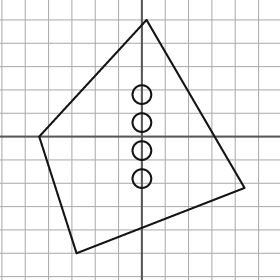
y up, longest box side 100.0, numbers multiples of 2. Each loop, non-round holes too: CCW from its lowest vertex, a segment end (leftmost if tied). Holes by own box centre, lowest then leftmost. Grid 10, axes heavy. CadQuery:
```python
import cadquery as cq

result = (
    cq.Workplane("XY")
    .moveTo(-28.0, -50.0)
    .lineTo(44.0, -22.0)
    .lineTo(2.0, 50.0)
    .lineTo(-44.0, 0.0)
    .close()
    .moveTo(0.0, -18.0)
    .circle(4.0)
    .moveTo(0.0, -6.0)
    .circle(4.0)
    .moveTo(0.0, 6.0)
    .circle(4.0)
    .moveTo(0.0, 18.0)
    .circle(4.0)
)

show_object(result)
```